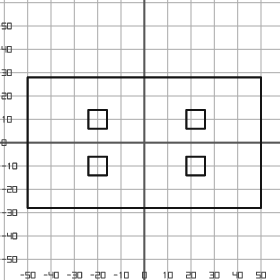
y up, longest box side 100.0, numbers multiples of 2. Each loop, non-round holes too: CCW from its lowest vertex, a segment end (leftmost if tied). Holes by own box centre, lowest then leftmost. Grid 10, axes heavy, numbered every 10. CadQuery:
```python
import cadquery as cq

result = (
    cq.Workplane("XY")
    .moveTo(-50.0, -28.0)
    .lineTo(50.0, -28.0)
    .lineTo(50.0, 28.0)
    .lineTo(-50.0, 28.0)
    .close()
    .moveTo(-24.0, -14.0)
    .lineTo(-16.0, -14.0)
    .lineTo(-16.0, -6.0)
    .lineTo(-24.0, -6.0)
    .close()
    .moveTo(18.0, -14.0)
    .lineTo(26.0, -14.0)
    .lineTo(26.0, -6.0)
    .lineTo(18.0, -6.0)
    .close()
    .moveTo(-24.0, 6.0)
    .lineTo(-16.0, 6.0)
    .lineTo(-16.0, 14.0)
    .lineTo(-24.0, 14.0)
    .close()
    .moveTo(18.0, 6.0)
    .lineTo(26.0, 6.0)
    .lineTo(26.0, 14.0)
    .lineTo(18.0, 14.0)
    .close()
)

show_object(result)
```